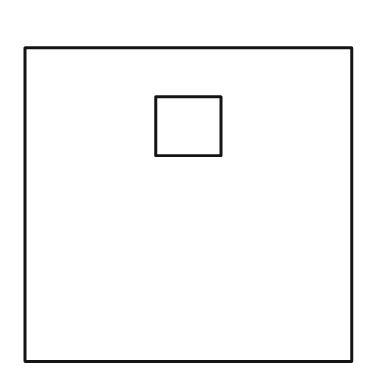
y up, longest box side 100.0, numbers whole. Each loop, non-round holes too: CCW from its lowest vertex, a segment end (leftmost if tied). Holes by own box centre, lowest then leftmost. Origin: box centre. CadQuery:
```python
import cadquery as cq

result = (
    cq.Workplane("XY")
    .moveTo(-50.0, -48.0)
    .lineTo(50.0, -48.0)
    .lineTo(50.0, 48.0)
    .lineTo(-50.0, 48.0)
    .close()
    .moveTo(-10.0, 15.0)
    .lineTo(10.0, 15.0)
    .lineTo(10.0, 33.0)
    .lineTo(-10.0, 33.0)
    .close()
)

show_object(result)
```